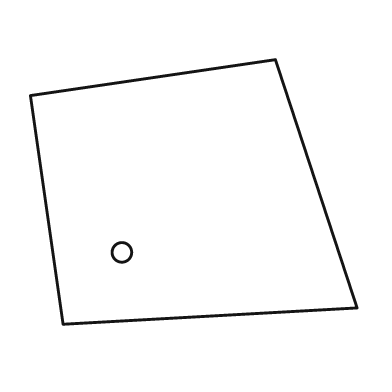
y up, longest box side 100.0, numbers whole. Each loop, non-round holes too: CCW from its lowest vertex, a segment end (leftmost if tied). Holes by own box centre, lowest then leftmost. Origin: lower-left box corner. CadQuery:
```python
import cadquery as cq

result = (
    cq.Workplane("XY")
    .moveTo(10.0, 0.0)
    .lineTo(100.0, 5.0)
    .lineTo(75.0, 81.0)
    .lineTo(0.0, 70.0)
    .close()
    .moveTo(28.0, 22.0)
    .circle(3.0)
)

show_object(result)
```